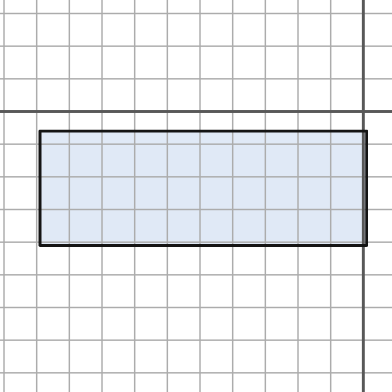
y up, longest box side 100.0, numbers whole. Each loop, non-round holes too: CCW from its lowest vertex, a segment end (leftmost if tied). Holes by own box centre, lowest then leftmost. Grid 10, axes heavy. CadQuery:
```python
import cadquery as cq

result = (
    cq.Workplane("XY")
    .moveTo(-99.0, -41.0)
    .lineTo(1.0, -41.0)
    .lineTo(1.0, -6.0)
    .lineTo(-99.0, -6.0)
    .close()
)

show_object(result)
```